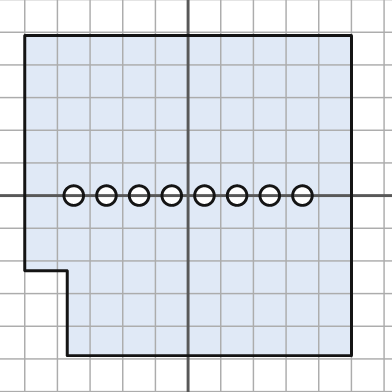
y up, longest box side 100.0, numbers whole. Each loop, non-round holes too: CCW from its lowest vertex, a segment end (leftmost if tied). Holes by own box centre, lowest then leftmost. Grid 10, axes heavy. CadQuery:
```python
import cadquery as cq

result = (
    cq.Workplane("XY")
    .moveTo(-37.0, -49.0)
    .lineTo(50.0, -49.0)
    .lineTo(50.0, 49.0)
    .lineTo(-50.0, 49.0)
    .lineTo(-50.0, -23.0)
    .lineTo(-37.0, -23.0)
    .close()
    .moveTo(-35.0, 0.0)
    .circle(3.0)
    .moveTo(-25.0, 0.0)
    .circle(3.0)
    .moveTo(-15.0, 0.0)
    .circle(3.0)
    .moveTo(-5.0, 0.0)
    .circle(3.0)
    .moveTo(5.0, 0.0)
    .circle(3.0)
    .moveTo(15.0, 0.0)
    .circle(3.0)
    .moveTo(25.0, 0.0)
    .circle(3.0)
    .moveTo(35.0, 0.0)
    .circle(3.0)
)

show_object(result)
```